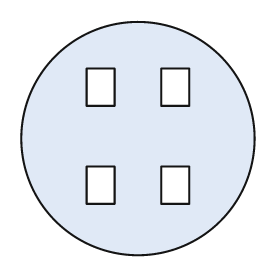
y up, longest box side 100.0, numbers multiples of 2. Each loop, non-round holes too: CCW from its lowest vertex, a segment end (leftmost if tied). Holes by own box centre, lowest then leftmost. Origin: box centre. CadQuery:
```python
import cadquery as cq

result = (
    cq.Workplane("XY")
    .moveTo(0.0, 0.0)
    .circle(50.0)
    .moveTo(-22.0, -28.0)
    .lineTo(-10.0, -28.0)
    .lineTo(-10.0, -12.0)
    .lineTo(-22.0, -12.0)
    .close()
    .moveTo(10.0, -28.0)
    .lineTo(22.0, -28.0)
    .lineTo(22.0, -12.0)
    .lineTo(10.0, -12.0)
    .close()
    .moveTo(-22.0, 14.0)
    .lineTo(-10.0, 14.0)
    .lineTo(-10.0, 30.0)
    .lineTo(-22.0, 30.0)
    .close()
    .moveTo(10.0, 14.0)
    .lineTo(22.0, 14.0)
    .lineTo(22.0, 30.0)
    .lineTo(10.0, 30.0)
    .close()
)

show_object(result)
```